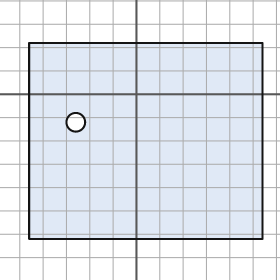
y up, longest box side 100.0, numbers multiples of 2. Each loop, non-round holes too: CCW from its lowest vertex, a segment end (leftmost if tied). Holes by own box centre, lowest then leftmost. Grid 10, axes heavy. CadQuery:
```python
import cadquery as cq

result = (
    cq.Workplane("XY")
    .moveTo(-46.0, -62.0)
    .lineTo(54.0, -62.0)
    .lineTo(54.0, 22.0)
    .lineTo(-46.0, 22.0)
    .close()
    .moveTo(-26.0, -12.0)
    .circle(4.0)
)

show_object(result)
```